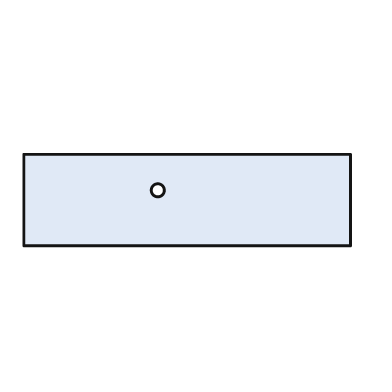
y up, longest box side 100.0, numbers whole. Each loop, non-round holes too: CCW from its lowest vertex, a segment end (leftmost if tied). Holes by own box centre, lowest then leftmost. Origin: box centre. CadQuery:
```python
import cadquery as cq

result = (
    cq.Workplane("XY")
    .moveTo(-50.0, -14.0)
    .lineTo(50.0, -14.0)
    .lineTo(50.0, 14.0)
    .lineTo(-50.0, 14.0)
    .close()
    .moveTo(-9.0, 3.0)
    .circle(2.0)
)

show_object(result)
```